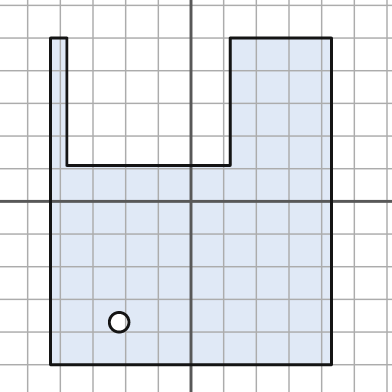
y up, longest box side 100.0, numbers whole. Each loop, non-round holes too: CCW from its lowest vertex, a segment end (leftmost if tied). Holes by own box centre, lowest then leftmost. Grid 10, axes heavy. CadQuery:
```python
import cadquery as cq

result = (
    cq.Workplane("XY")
    .moveTo(-43.0, -50.0)
    .lineTo(43.0, -50.0)
    .lineTo(43.0, 50.0)
    .lineTo(12.0, 50.0)
    .lineTo(12.0, 11.0)
    .lineTo(-38.0, 11.0)
    .lineTo(-38.0, 50.0)
    .lineTo(-43.0, 50.0)
    .close()
    .moveTo(-22.0, -37.0)
    .circle(3.0)
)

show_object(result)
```